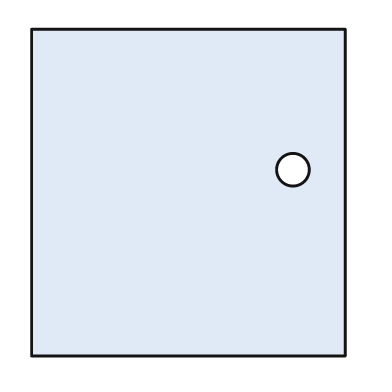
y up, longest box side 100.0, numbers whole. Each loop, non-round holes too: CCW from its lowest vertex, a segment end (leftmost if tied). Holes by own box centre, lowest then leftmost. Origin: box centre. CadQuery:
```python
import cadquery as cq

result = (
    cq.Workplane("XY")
    .moveTo(-48.0, -50.0)
    .lineTo(48.0, -50.0)
    .lineTo(48.0, 50.0)
    .lineTo(-48.0, 50.0)
    .close()
    .moveTo(32.0, 7.0)
    .circle(5.0)
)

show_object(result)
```